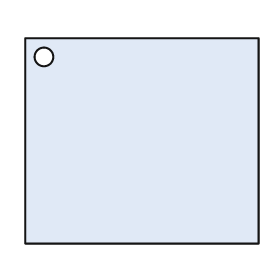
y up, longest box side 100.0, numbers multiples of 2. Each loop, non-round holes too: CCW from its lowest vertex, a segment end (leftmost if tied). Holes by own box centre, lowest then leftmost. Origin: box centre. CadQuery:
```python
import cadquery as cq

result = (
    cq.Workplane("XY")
    .moveTo(-50.0, -44.0)
    .lineTo(50.0, -44.0)
    .lineTo(50.0, 44.0)
    .lineTo(-50.0, 44.0)
    .close()
    .moveTo(-42.0, 36.0)
    .circle(4.0)
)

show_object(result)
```